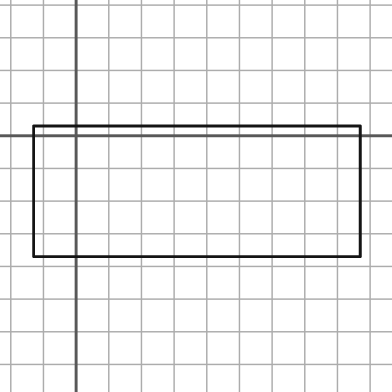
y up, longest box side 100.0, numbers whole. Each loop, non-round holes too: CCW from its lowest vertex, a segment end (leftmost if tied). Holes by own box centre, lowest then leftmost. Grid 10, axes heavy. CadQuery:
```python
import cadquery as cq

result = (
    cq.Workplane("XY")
    .moveTo(-13.0, -37.0)
    .lineTo(87.0, -37.0)
    .lineTo(87.0, 3.0)
    .lineTo(-13.0, 3.0)
    .close()
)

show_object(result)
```